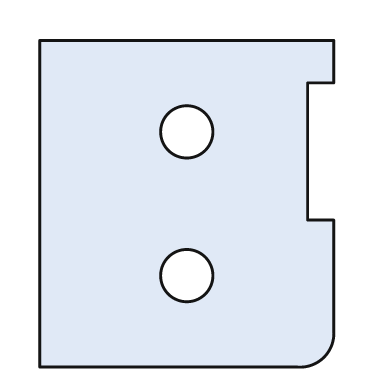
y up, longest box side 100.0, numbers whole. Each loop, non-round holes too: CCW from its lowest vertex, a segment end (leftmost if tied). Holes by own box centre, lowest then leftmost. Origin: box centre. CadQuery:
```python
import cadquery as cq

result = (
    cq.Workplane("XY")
    .moveTo(-45.0, -50.0)
    .lineTo(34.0, -50.0)
    .threePointArc((42.0, -47.0), (45.0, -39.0))
    .lineTo(45.0, -5.0)
    .lineTo(37.0, -5.0)
    .lineTo(37.0, 37.0)
    .lineTo(45.0, 37.0)
    .lineTo(45.0, 50.0)
    .lineTo(-45.0, 50.0)
    .close()
    .moveTo(0.0, -22.0)
    .circle(8.0)
    .moveTo(0.0, 22.0)
    .circle(8.0)
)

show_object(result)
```